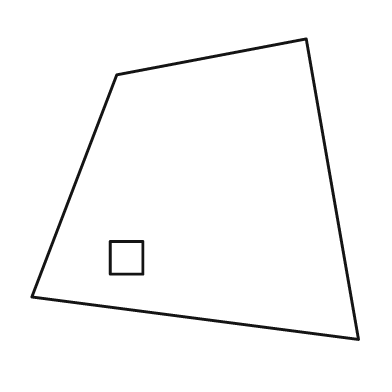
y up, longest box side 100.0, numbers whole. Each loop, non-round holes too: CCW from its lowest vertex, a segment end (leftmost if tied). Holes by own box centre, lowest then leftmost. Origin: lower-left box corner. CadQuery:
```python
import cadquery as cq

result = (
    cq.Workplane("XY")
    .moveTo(100.0, 0.0)
    .lineTo(84.0, 92.0)
    .lineTo(26.0, 81.0)
    .lineTo(0.0, 13.0)
    .close()
    .moveTo(24.0, 20.0)
    .lineTo(34.0, 20.0)
    .lineTo(34.0, 30.0)
    .lineTo(24.0, 30.0)
    .close()
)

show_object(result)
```